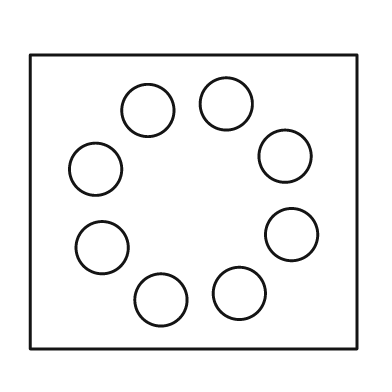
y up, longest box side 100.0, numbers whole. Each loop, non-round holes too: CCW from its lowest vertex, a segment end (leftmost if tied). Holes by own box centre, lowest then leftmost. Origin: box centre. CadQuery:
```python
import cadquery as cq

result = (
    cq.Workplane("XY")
    .moveTo(-50.0, -45.0)
    .lineTo(50.0, -45.0)
    .lineTo(50.0, 45.0)
    .lineTo(-50.0, 45.0)
    .close()
    .moveTo(-10.0, -30.0)
    .circle(8.0)
    .moveTo(14.0, -28.0)
    .circle(8.0)
    .moveTo(-28.0, -14.0)
    .circle(8.0)
    .moveTo(30.0, -10.0)
    .circle(8.0)
    .moveTo(-30.0, 10.0)
    .circle(8.0)
    .moveTo(28.0, 14.0)
    .circle(8.0)
    .moveTo(-14.0, 28.0)
    .circle(8.0)
    .moveTo(10.0, 30.0)
    .circle(8.0)
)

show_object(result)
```